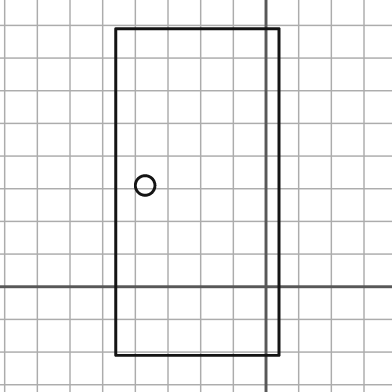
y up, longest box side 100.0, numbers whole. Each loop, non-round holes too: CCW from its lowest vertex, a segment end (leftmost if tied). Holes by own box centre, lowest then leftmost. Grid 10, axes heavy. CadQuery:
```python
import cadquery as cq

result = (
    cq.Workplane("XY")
    .moveTo(-46.0, -21.0)
    .lineTo(4.0, -21.0)
    .lineTo(4.0, 79.0)
    .lineTo(-46.0, 79.0)
    .close()
    .moveTo(-37.0, 31.0)
    .circle(3.0)
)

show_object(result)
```